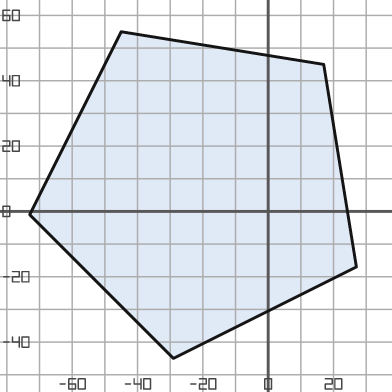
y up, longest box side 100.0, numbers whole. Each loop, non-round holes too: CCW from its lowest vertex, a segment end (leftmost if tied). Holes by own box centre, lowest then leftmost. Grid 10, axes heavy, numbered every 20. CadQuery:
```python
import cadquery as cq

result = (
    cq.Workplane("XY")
    .moveTo(-29.0, -45.0)
    .lineTo(27.0, -17.0)
    .lineTo(17.0, 45.0)
    .lineTo(-45.0, 55.0)
    .lineTo(-73.0, -1.0)
    .close()
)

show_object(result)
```